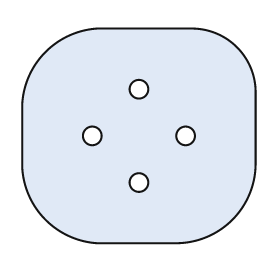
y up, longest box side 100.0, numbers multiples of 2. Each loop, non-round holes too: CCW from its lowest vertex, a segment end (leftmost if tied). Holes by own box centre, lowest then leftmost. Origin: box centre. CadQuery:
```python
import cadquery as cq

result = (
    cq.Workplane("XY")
    .moveTo(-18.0, -46.0)
    .lineTo(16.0, -46.0)
    .threePointArc((40.0, -36.0), (50.0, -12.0))
    .lineTo(50.0, 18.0)
    .threePointArc((42.0, 38.0), (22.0, 46.0))
    .lineTo(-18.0, 46.0)
    .threePointArc((-40.0, 36.0), (-50.0, 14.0))
    .lineTo(-50.0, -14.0)
    .threePointArc((-40.0, -36.0), (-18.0, -46.0))
    .close()
    .moveTo(0.0, -20.0)
    .circle(4.0)
    .moveTo(-20.0, 0.0)
    .circle(4.0)
    .moveTo(20.0, 0.0)
    .circle(4.0)
    .moveTo(0.0, 20.0)
    .circle(4.0)
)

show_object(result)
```